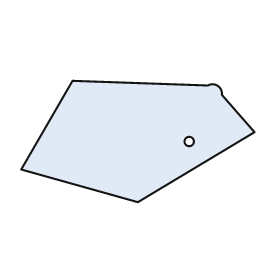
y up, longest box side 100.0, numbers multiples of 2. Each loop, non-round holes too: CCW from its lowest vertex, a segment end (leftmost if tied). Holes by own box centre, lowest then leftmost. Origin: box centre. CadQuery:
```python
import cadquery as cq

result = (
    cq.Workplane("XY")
    .moveTo(0.0, -26.0)
    .lineTo(50.0, 4.0)
    .lineTo(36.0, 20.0)
    .threePointArc((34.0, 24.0), (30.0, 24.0))
    .lineTo(-28.0, 26.0)
    .lineTo(-50.0, -12.0)
    .close()
    .moveTo(22.0, 0.0)
    .circle(2.0)
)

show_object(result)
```